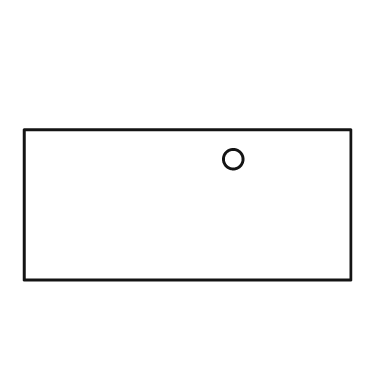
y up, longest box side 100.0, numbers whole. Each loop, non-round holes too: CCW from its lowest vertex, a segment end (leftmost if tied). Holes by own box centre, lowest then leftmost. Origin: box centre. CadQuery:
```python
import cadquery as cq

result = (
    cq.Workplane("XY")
    .moveTo(-50.0, -23.0)
    .lineTo(50.0, -23.0)
    .lineTo(50.0, 23.0)
    .lineTo(-50.0, 23.0)
    .close()
    .moveTo(14.0, 14.0)
    .circle(3.0)
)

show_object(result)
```